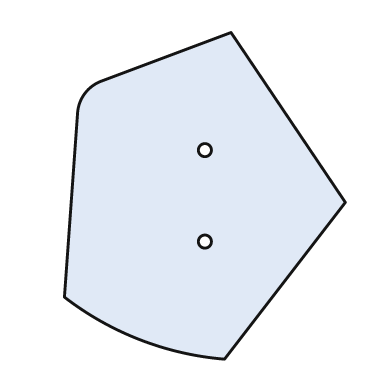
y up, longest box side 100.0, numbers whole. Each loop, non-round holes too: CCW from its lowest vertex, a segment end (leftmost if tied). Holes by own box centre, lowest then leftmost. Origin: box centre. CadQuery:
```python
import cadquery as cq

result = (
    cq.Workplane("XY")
    .moveTo(6.0, -50.0)
    .lineTo(43.0, -2.0)
    .lineTo(8.0, 50.0)
    .lineTo(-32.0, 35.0)
    .threePointArc((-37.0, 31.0), (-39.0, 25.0))
    .lineTo(-43.0, -31.0)
    .threePointArc((-20.0, -44.0), (6.0, -50.0))
    .close()
    .moveTo(0.0, -14.0)
    .circle(2.0)
    .moveTo(0.0, 14.0)
    .circle(2.0)
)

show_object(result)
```